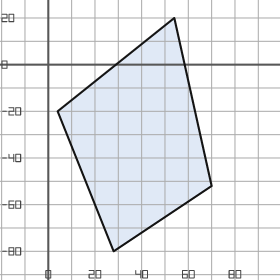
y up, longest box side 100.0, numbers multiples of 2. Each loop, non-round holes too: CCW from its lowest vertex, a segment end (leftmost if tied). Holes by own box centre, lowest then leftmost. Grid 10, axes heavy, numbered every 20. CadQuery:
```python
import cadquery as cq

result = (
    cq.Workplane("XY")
    .moveTo(28.0, -80.0)
    .lineTo(70.0, -52.0)
    .lineTo(54.0, 20.0)
    .lineTo(4.0, -20.0)
    .close()
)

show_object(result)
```